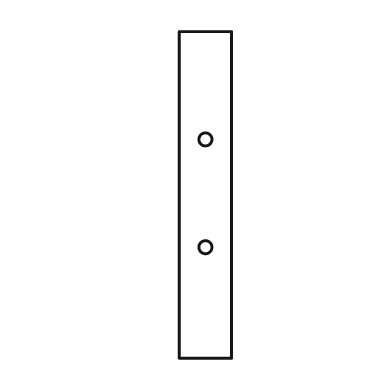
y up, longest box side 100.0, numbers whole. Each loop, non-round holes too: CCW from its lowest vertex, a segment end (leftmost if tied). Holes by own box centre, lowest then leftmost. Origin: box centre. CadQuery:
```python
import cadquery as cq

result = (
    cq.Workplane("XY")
    .moveTo(-8.0, -50.0)
    .lineTo(8.0, -50.0)
    .lineTo(8.0, 50.0)
    .lineTo(-8.0, 50.0)
    .close()
    .moveTo(0.0, -16.0)
    .circle(2.0)
    .moveTo(0.0, 17.0)
    .circle(2.0)
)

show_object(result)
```